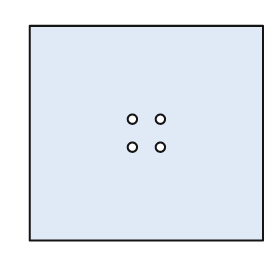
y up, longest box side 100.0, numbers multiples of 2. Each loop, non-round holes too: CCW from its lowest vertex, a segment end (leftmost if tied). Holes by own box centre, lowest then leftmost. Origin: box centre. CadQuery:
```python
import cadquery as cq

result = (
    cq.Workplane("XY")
    .moveTo(-50.0, -46.0)
    .lineTo(50.0, -46.0)
    .lineTo(50.0, 46.0)
    .lineTo(-50.0, 46.0)
    .close()
    .moveTo(-6.0, -6.0)
    .circle(2.0)
    .moveTo(6.0, -6.0)
    .circle(2.0)
    .moveTo(-6.0, 6.0)
    .circle(2.0)
    .moveTo(6.0, 6.0)
    .circle(2.0)
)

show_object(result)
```